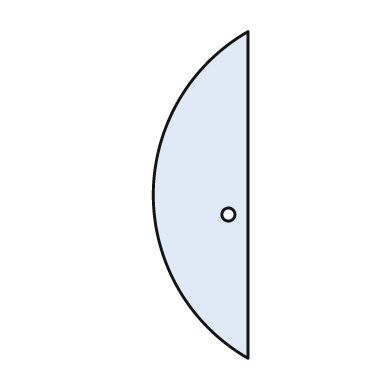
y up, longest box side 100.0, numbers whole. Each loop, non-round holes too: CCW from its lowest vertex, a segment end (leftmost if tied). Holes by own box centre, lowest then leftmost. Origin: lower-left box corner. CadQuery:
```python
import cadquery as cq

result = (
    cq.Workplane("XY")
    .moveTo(29.0, 0.0)
    .lineTo(29.0, 100.0)
    .threePointArc((0.0, 50.0), (29.0, 0.0))
    .close()
    .moveTo(23.0, 44.0)
    .circle(2.0)
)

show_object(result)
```